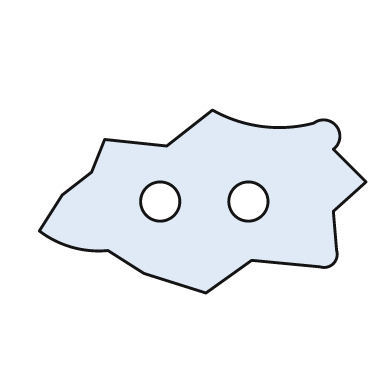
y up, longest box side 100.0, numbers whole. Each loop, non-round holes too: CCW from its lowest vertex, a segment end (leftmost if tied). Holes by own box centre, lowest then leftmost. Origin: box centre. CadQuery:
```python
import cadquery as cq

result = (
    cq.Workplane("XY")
    .moveTo(1.0, -28.0)
    .lineTo(15.0, -18.0)
    .lineTo(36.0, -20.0)
    .threePointArc((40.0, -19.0), (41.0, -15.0))
    .lineTo(40.0, -3.0)
    .lineTo(50.0, 6.0)
    .lineTo(40.0, 16.0)
    .threePointArc((41.0, 23.0), (34.0, 24.0))
    .threePointArc((18.0, 23.0), (3.0, 28.0))
    .lineTo(-11.0, 17.0)
    .lineTo(-30.0, 19.0)
    .lineTo(-34.0, 9.0)
    .lineTo(-43.0, 2.0)
    .lineTo(-50.0, -9.0)
    .threePointArc((-40.0, -14.0), (-29.0, -15.0))
    .lineTo(-18.0, -22.0)
    .close()
    .moveTo(-13.0, 0.0)
    .circle(6.0)
    .moveTo(14.0, 0.0)
    .circle(6.0)
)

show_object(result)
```